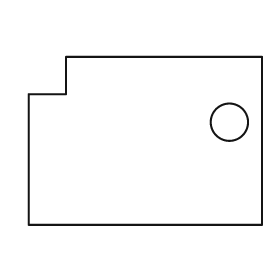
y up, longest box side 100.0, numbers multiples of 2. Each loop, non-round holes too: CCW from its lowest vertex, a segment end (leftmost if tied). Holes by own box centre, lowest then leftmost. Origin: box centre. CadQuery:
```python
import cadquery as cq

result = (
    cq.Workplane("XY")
    .moveTo(-50.0, -36.0)
    .lineTo(50.0, -36.0)
    .lineTo(50.0, 36.0)
    .lineTo(-34.0, 36.0)
    .lineTo(-34.0, 20.0)
    .lineTo(-50.0, 20.0)
    .close()
    .moveTo(36.0, 8.0)
    .circle(8.0)
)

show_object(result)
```